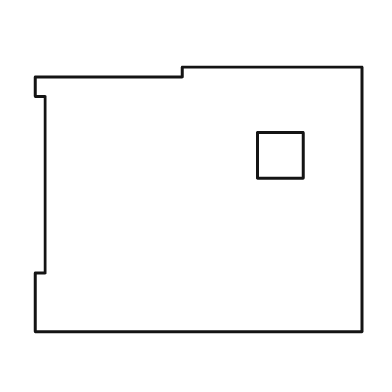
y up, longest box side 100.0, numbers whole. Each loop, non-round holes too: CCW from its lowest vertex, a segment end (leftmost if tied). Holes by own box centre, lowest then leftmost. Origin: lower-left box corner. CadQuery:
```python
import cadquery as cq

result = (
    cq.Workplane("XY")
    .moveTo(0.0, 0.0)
    .lineTo(100.0, 0.0)
    .lineTo(100.0, 81.0)
    .lineTo(45.0, 81.0)
    .lineTo(45.0, 78.0)
    .lineTo(0.0, 78.0)
    .lineTo(0.0, 72.0)
    .lineTo(3.0, 72.0)
    .lineTo(3.0, 18.0)
    .lineTo(0.0, 18.0)
    .close()
    .moveTo(68.0, 47.0)
    .lineTo(82.0, 47.0)
    .lineTo(82.0, 61.0)
    .lineTo(68.0, 61.0)
    .close()
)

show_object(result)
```